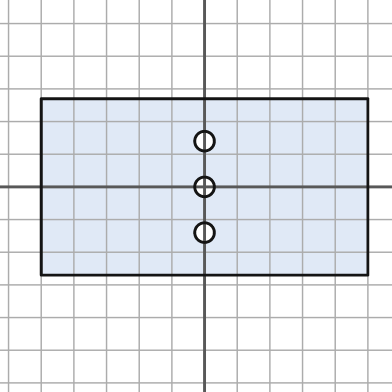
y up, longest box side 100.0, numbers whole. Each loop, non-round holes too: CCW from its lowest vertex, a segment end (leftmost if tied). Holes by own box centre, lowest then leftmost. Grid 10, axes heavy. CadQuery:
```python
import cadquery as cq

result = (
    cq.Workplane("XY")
    .moveTo(-50.0, -27.0)
    .lineTo(50.0, -27.0)
    .lineTo(50.0, 27.0)
    .lineTo(-50.0, 27.0)
    .close()
    .moveTo(0.0, -14.0)
    .circle(3.0)
    .moveTo(0.0, 0.0)
    .circle(3.0)
    .moveTo(0.0, 14.0)
    .circle(3.0)
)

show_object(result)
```